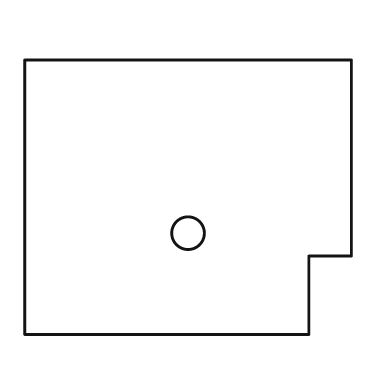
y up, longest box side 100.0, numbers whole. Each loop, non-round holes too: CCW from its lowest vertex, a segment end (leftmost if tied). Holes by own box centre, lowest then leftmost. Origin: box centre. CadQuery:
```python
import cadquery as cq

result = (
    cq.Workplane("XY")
    .moveTo(-50.0, -42.0)
    .lineTo(37.0, -42.0)
    .lineTo(37.0, -18.0)
    .lineTo(50.0, -18.0)
    .lineTo(50.0, 42.0)
    .lineTo(-50.0, 42.0)
    .close()
    .moveTo(0.0, -11.0)
    .circle(5.0)
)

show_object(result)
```